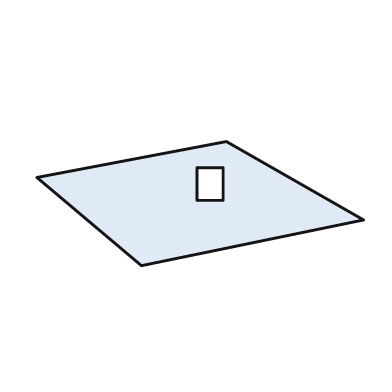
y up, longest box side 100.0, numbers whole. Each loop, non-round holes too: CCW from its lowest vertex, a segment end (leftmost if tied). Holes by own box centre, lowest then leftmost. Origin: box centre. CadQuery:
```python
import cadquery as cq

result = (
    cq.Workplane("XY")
    .moveTo(-18.0, -19.0)
    .lineTo(50.0, -5.0)
    .lineTo(8.0, 19.0)
    .lineTo(-50.0, 8.0)
    .close()
    .moveTo(-1.0, 1.0)
    .lineTo(7.0, 1.0)
    .lineTo(7.0, 11.0)
    .lineTo(-1.0, 11.0)
    .close()
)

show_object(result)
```